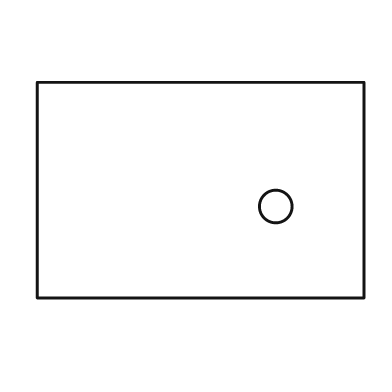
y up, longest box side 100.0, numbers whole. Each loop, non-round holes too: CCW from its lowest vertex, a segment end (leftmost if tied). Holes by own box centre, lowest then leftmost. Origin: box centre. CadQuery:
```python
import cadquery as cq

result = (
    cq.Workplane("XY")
    .moveTo(-50.0, -33.0)
    .lineTo(50.0, -33.0)
    .lineTo(50.0, 33.0)
    .lineTo(-50.0, 33.0)
    .close()
    .moveTo(23.0, -5.0)
    .circle(5.0)
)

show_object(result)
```